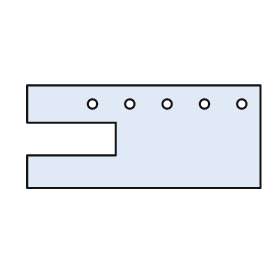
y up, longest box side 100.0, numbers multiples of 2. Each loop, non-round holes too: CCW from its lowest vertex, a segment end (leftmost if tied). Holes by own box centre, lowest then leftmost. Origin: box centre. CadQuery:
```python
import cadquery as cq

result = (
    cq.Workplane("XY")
    .moveTo(-50.0, -22.0)
    .lineTo(50.0, -22.0)
    .lineTo(50.0, 22.0)
    .lineTo(-50.0, 22.0)
    .lineTo(-50.0, 6.0)
    .lineTo(-12.0, 6.0)
    .lineTo(-12.0, -8.0)
    .lineTo(-50.0, -8.0)
    .close()
    .moveTo(-22.0, 14.0)
    .circle(2.0)
    .moveTo(-6.0, 14.0)
    .circle(2.0)
    .moveTo(10.0, 14.0)
    .circle(2.0)
    .moveTo(26.0, 14.0)
    .circle(2.0)
    .moveTo(42.0, 14.0)
    .circle(2.0)
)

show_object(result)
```